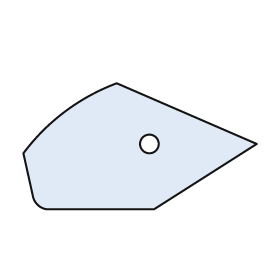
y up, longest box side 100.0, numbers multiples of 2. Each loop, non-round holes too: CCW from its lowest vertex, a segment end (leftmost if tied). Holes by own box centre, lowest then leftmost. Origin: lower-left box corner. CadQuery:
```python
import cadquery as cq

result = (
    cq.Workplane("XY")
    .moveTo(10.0, 0.0)
    .lineTo(56.0, 0.0)
    .lineTo(100.0, 28.0)
    .lineTo(40.0, 54.0)
    .threePointArc((18.0, 42.0), (0.0, 24.0))
    .lineTo(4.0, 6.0)
    .threePointArc((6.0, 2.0), (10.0, 0.0))
    .close()
    .moveTo(54.0, 28.0)
    .circle(4.0)
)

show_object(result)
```